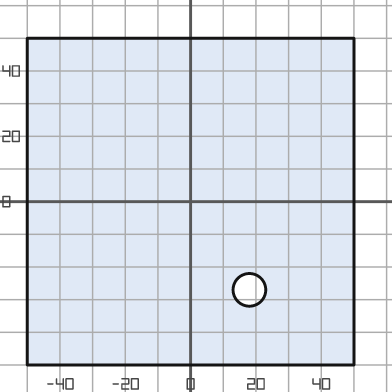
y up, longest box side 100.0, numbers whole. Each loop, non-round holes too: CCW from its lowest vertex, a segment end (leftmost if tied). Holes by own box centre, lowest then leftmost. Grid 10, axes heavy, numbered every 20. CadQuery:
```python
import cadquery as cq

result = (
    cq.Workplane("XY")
    .moveTo(-50.0, -50.0)
    .lineTo(50.0, -50.0)
    .lineTo(50.0, 50.0)
    .lineTo(-50.0, 50.0)
    .close()
    .moveTo(18.0, -27.0)
    .circle(5.0)
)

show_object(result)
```